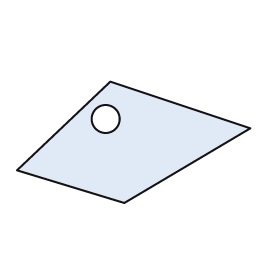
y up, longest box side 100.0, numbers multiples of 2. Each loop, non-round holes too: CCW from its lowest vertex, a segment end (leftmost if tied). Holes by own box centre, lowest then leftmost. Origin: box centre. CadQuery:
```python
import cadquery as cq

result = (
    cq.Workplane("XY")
    .moveTo(-4.0, -26.0)
    .lineTo(50.0, 6.0)
    .lineTo(-10.0, 26.0)
    .lineTo(-50.0, -12.0)
    .close()
    .moveTo(-12.0, 10.0)
    .circle(6.0)
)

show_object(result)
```